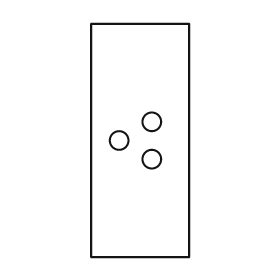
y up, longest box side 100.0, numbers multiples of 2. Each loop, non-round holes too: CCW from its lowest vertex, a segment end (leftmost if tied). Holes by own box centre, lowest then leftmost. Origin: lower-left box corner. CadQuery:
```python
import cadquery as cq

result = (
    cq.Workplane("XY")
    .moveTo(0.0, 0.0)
    .lineTo(42.0, 0.0)
    .lineTo(42.0, 100.0)
    .lineTo(0.0, 100.0)
    .close()
    .moveTo(26.0, 42.0)
    .circle(4.0)
    .moveTo(12.0, 50.0)
    .circle(4.0)
    .moveTo(26.0, 58.0)
    .circle(4.0)
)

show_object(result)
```